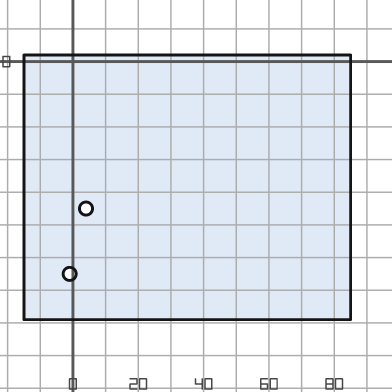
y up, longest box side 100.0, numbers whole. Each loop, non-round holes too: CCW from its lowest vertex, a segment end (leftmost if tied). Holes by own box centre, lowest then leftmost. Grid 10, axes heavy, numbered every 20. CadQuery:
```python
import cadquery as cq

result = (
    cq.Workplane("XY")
    .moveTo(-15.0, -79.0)
    .lineTo(85.0, -79.0)
    .lineTo(85.0, 2.0)
    .lineTo(-15.0, 2.0)
    .close()
    .moveTo(-1.0, -65.0)
    .circle(2.0)
    .moveTo(4.0, -45.0)
    .circle(2.0)
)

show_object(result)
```